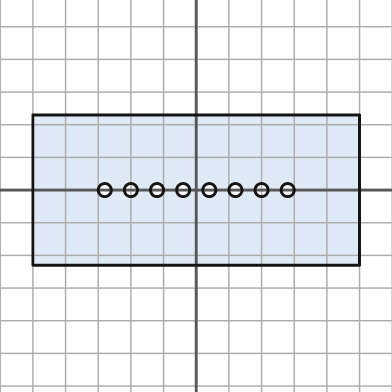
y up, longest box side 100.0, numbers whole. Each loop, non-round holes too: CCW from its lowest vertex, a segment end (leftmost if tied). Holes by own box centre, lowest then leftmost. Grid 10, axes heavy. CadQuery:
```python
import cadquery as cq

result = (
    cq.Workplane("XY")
    .moveTo(-50.0, -23.0)
    .lineTo(50.0, -23.0)
    .lineTo(50.0, 23.0)
    .lineTo(-50.0, 23.0)
    .close()
    .moveTo(-28.0, 0.0)
    .circle(2.0)
    .moveTo(-20.0, 0.0)
    .circle(2.0)
    .moveTo(-12.0, 0.0)
    .circle(2.0)
    .moveTo(-4.0, 0.0)
    .circle(2.0)
    .moveTo(4.0, 0.0)
    .circle(2.0)
    .moveTo(12.0, 0.0)
    .circle(2.0)
    .moveTo(20.0, 0.0)
    .circle(2.0)
    .moveTo(28.0, 0.0)
    .circle(2.0)
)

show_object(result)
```